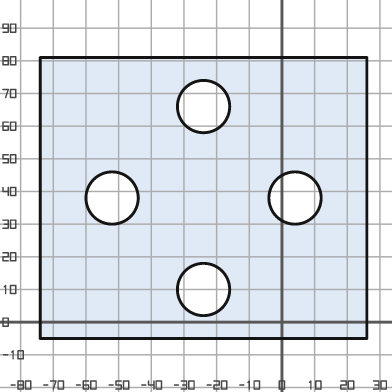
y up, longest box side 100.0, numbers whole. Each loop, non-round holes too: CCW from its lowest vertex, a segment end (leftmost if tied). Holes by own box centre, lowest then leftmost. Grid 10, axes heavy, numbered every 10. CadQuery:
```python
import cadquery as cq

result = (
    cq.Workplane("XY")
    .moveTo(-74.0, -5.0)
    .lineTo(26.0, -5.0)
    .lineTo(26.0, 81.0)
    .lineTo(-74.0, 81.0)
    .close()
    .moveTo(-24.0, 10.0)
    .circle(8.0)
    .moveTo(-52.0, 38.0)
    .circle(8.0)
    .moveTo(4.0, 38.0)
    .circle(8.0)
    .moveTo(-24.0, 66.0)
    .circle(8.0)
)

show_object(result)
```